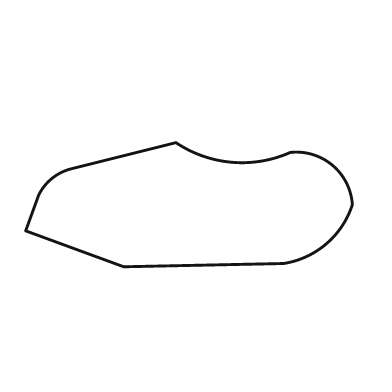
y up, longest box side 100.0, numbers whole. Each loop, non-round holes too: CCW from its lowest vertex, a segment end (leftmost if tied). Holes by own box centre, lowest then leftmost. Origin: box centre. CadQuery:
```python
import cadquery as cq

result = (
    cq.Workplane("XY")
    .moveTo(-20.0, -19.0)
    .lineTo(29.0, -18.0)
    .threePointArc((42.0, -12.0), (50.0, 0.0))
    .threePointArc((44.0, 12.0), (31.0, 16.0))
    .threePointArc((13.0, 13.0), (-4.0, 19.0))
    .lineTo(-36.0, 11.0)
    .threePointArc((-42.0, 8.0), (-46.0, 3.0))
    .lineTo(-50.0, -8.0)
    .close()
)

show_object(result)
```